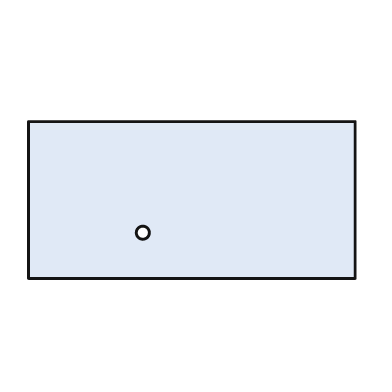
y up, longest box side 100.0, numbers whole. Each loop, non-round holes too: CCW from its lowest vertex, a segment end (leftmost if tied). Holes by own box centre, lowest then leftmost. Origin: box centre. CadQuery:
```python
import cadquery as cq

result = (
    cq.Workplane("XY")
    .moveTo(-50.0, -24.0)
    .lineTo(50.0, -24.0)
    .lineTo(50.0, 24.0)
    .lineTo(-50.0, 24.0)
    .close()
    .moveTo(-15.0, -10.0)
    .circle(2.0)
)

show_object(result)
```